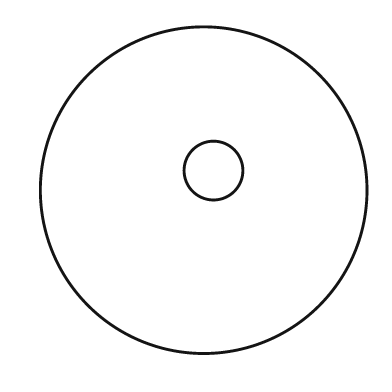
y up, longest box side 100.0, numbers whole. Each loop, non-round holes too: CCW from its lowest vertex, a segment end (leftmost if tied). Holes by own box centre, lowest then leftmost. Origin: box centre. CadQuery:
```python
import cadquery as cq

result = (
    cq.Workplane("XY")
    .moveTo(0.0, 0.0)
    .circle(50.0)
    .moveTo(3.0, 6.0)
    .circle(9.0)
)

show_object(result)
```